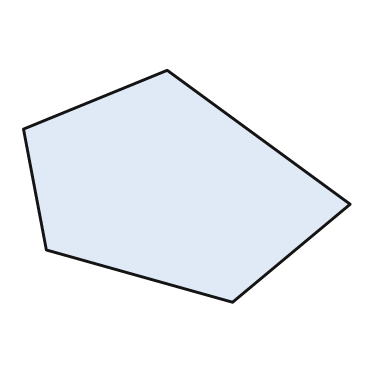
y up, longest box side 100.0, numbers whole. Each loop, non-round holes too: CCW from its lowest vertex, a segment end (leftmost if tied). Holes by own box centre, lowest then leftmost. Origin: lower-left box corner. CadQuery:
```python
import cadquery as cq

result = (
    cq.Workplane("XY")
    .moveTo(64.0, 0.0)
    .lineTo(100.0, 30.0)
    .lineTo(44.0, 71.0)
    .lineTo(0.0, 53.0)
    .lineTo(7.0, 16.0)
    .close()
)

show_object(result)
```